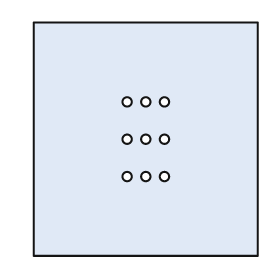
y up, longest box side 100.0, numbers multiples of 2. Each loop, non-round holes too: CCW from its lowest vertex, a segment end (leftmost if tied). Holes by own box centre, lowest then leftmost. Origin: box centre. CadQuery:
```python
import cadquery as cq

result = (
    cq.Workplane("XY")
    .moveTo(-48.0, -50.0)
    .lineTo(48.0, -50.0)
    .lineTo(48.0, 50.0)
    .lineTo(-48.0, 50.0)
    .close()
    .moveTo(-8.0, -16.0)
    .circle(2.0)
    .moveTo(0.0, -16.0)
    .circle(2.0)
    .moveTo(8.0, -16.0)
    .circle(2.0)
    .moveTo(-8.0, 0.0)
    .circle(2.0)
    .moveTo(0.0, 0.0)
    .circle(2.0)
    .moveTo(8.0, 0.0)
    .circle(2.0)
    .moveTo(-8.0, 16.0)
    .circle(2.0)
    .moveTo(0.0, 16.0)
    .circle(2.0)
    .moveTo(8.0, 16.0)
    .circle(2.0)
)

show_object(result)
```